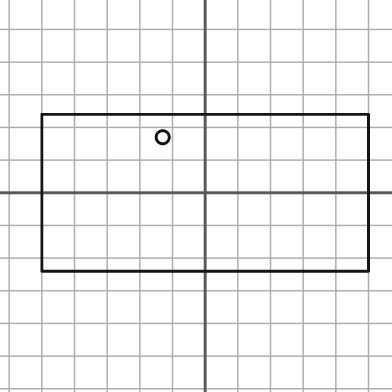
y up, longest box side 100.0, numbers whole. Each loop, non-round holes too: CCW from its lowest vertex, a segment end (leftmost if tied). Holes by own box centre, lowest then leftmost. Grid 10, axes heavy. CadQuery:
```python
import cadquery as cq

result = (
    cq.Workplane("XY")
    .moveTo(-50.0, -24.0)
    .lineTo(50.0, -24.0)
    .lineTo(50.0, 24.0)
    .lineTo(-50.0, 24.0)
    .close()
    .moveTo(-13.0, 17.0)
    .circle(2.0)
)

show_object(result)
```